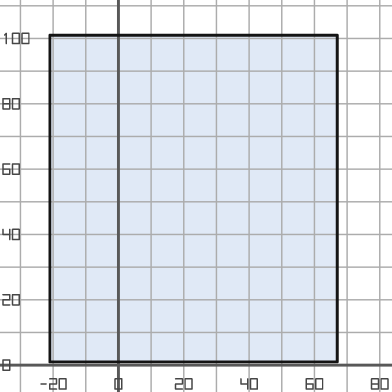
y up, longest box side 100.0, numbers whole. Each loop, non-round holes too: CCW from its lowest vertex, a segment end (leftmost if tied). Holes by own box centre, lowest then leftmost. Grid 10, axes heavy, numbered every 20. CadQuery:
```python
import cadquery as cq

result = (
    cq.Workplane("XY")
    .moveTo(-21.0, 1.0)
    .lineTo(67.0, 1.0)
    .lineTo(67.0, 101.0)
    .lineTo(-21.0, 101.0)
    .close()
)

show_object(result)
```